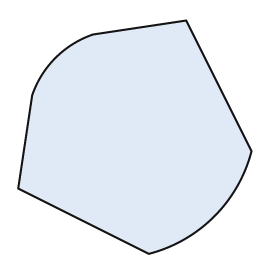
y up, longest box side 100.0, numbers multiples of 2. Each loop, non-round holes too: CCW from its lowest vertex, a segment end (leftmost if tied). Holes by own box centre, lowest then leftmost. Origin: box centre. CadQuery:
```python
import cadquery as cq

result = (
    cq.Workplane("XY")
    .moveTo(6.0, -50.0)
    .threePointArc((34.0, -34.0), (50.0, -6.0))
    .lineTo(22.0, 50.0)
    .lineTo(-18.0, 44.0)
    .threePointArc((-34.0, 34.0), (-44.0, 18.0))
    .lineTo(-50.0, -22.0)
    .close()
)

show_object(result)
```